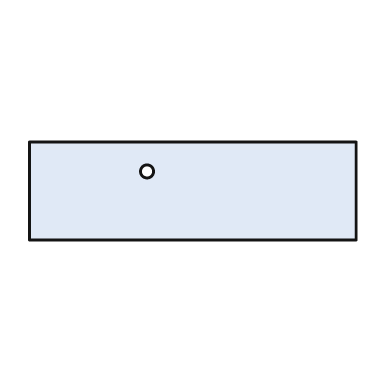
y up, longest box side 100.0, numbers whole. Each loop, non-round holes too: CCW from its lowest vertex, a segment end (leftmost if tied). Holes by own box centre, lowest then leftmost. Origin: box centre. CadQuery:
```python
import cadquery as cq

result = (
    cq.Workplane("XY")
    .moveTo(-50.0, -15.0)
    .lineTo(50.0, -15.0)
    .lineTo(50.0, 15.0)
    .lineTo(-50.0, 15.0)
    .close()
    .moveTo(-14.0, 6.0)
    .circle(2.0)
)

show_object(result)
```